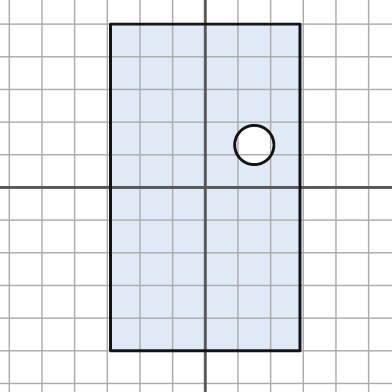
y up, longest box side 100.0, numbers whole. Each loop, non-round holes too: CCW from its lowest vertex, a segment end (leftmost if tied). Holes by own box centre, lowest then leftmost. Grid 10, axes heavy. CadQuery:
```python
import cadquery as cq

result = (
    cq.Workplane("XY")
    .moveTo(-29.0, -50.0)
    .lineTo(29.0, -50.0)
    .lineTo(29.0, 50.0)
    .lineTo(-29.0, 50.0)
    .close()
    .moveTo(15.0, 13.0)
    .circle(6.0)
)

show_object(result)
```